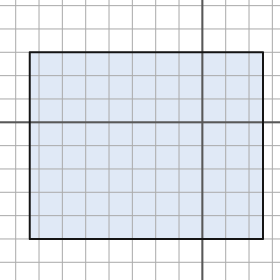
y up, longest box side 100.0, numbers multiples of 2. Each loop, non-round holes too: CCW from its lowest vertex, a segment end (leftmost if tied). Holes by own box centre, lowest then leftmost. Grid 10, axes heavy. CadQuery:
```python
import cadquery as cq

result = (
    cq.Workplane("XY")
    .moveTo(-74.0, -50.0)
    .lineTo(26.0, -50.0)
    .lineTo(26.0, 30.0)
    .lineTo(-74.0, 30.0)
    .close()
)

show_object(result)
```